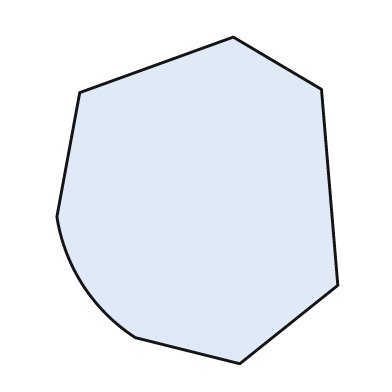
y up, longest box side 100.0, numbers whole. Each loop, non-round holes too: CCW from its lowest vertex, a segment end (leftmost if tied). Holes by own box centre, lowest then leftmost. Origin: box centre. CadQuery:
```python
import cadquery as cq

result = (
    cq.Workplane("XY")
    .moveTo(13.0, -50.0)
    .lineTo(43.0, -26.0)
    .lineTo(38.0, 34.0)
    .lineTo(11.0, 50.0)
    .lineTo(-36.0, 33.0)
    .lineTo(-43.0, -5.0)
    .threePointArc((-35.0, -26.0), (-19.0, -42.0))
    .close()
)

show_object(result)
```